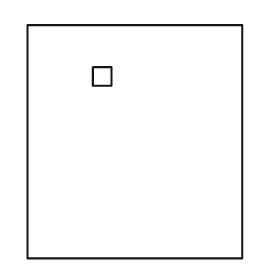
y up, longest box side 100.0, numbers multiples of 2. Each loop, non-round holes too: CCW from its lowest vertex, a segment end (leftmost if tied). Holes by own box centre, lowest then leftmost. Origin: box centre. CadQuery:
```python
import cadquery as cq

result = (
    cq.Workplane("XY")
    .moveTo(-46.0, -50.0)
    .lineTo(46.0, -50.0)
    .lineTo(46.0, 50.0)
    .lineTo(-46.0, 50.0)
    .close()
    .moveTo(-18.0, 24.0)
    .lineTo(-10.0, 24.0)
    .lineTo(-10.0, 32.0)
    .lineTo(-18.0, 32.0)
    .close()
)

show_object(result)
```